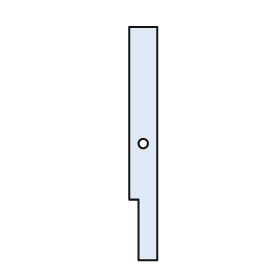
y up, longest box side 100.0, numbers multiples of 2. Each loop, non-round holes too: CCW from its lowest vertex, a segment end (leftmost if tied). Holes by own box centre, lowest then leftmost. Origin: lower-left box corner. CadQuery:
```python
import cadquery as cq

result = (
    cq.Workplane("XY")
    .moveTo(4.0, 0.0)
    .lineTo(12.0, 0.0)
    .lineTo(12.0, 100.0)
    .lineTo(0.0, 100.0)
    .lineTo(0.0, 26.0)
    .lineTo(4.0, 26.0)
    .close()
    .moveTo(6.0, 50.0)
    .circle(2.0)
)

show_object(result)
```